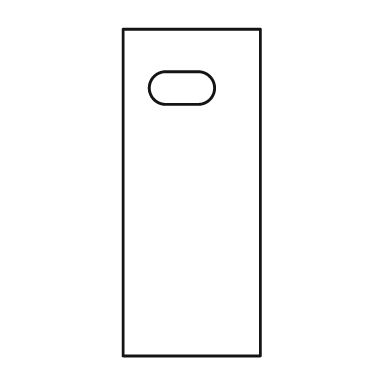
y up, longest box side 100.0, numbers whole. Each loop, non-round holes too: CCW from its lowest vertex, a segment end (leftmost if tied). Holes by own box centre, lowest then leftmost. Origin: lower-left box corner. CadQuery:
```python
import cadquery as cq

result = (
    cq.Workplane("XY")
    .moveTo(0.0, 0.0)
    .lineTo(42.0, 0.0)
    .lineTo(42.0, 100.0)
    .lineTo(0.0, 100.0)
    .close()
    .moveTo(13.0, 77.0)
    .lineTo(23.0, 77.0)
    .threePointArc((28.0, 82.0), (23.0, 87.0))
    .lineTo(13.0, 87.0)
    .threePointArc((8.0, 82.0), (13.0, 77.0))
    .close()
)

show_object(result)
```